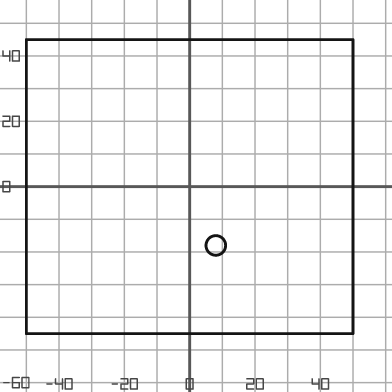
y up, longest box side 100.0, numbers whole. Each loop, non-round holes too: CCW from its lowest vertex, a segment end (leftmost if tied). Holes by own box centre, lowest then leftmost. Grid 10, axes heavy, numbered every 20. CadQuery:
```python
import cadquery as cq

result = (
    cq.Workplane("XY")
    .moveTo(-50.0, -45.0)
    .lineTo(50.0, -45.0)
    .lineTo(50.0, 45.0)
    .lineTo(-50.0, 45.0)
    .close()
    .moveTo(8.0, -18.0)
    .circle(3.0)
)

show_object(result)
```